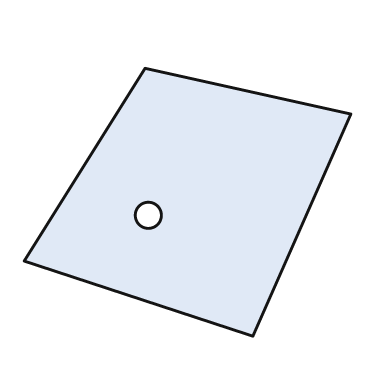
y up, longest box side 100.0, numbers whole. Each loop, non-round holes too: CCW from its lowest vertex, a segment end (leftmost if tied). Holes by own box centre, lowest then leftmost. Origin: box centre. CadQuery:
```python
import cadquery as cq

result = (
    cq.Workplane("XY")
    .moveTo(20.0, -41.0)
    .lineTo(50.0, 27.0)
    .lineTo(-13.0, 41.0)
    .lineTo(-50.0, -18.0)
    .close()
    .moveTo(-12.0, -4.0)
    .circle(4.0)
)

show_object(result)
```